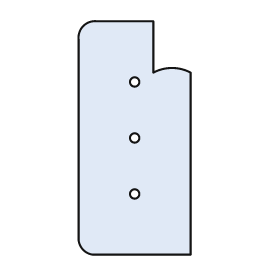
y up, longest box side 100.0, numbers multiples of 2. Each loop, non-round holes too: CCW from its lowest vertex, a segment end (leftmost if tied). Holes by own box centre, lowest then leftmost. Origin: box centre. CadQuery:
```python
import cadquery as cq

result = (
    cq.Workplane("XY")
    .moveTo(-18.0, -50.0)
    .lineTo(24.0, -50.0)
    .lineTo(24.0, 28.0)
    .threePointArc((16.0, 30.0), (8.0, 28.0))
    .lineTo(8.0, 50.0)
    .lineTo(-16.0, 50.0)
    .threePointArc((-22.0, 48.0), (-24.0, 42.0))
    .lineTo(-24.0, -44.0)
    .threePointArc((-22.0, -48.0), (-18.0, -50.0))
    .close()
    .moveTo(0.0, -24.0)
    .circle(2.0)
    .moveTo(0.0, 0.0)
    .circle(2.0)
    .moveTo(0.0, 24.0)
    .circle(2.0)
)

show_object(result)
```